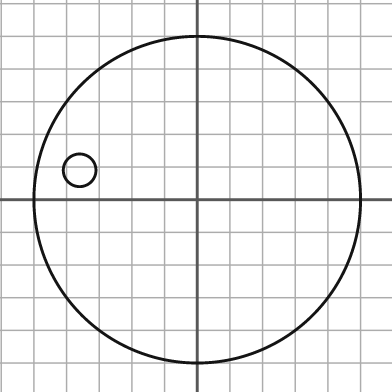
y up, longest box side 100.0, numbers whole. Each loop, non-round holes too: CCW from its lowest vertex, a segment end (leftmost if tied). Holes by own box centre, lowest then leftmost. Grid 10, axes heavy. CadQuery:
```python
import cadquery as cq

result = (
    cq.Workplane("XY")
    .moveTo(0.0, 0.0)
    .circle(50.0)
    .moveTo(-36.0, 9.0)
    .circle(5.0)
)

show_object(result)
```